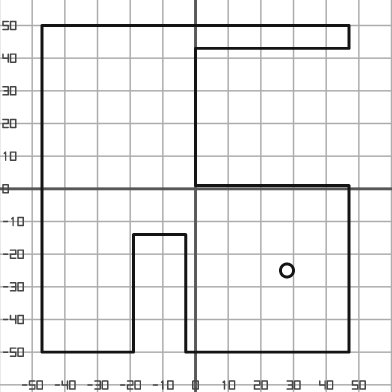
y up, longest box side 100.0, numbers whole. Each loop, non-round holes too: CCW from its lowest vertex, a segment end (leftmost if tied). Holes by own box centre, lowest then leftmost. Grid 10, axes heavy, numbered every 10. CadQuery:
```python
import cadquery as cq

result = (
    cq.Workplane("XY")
    .moveTo(-47.0, -50.0)
    .lineTo(-19.0, -50.0)
    .lineTo(-19.0, -14.0)
    .lineTo(-3.0, -14.0)
    .lineTo(-3.0, -50.0)
    .lineTo(47.0, -50.0)
    .lineTo(47.0, 1.0)
    .lineTo(0.0, 1.0)
    .lineTo(0.0, 43.0)
    .lineTo(47.0, 43.0)
    .lineTo(47.0, 50.0)
    .lineTo(-47.0, 50.0)
    .close()
    .moveTo(28.0, -25.0)
    .circle(2.0)
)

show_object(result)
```